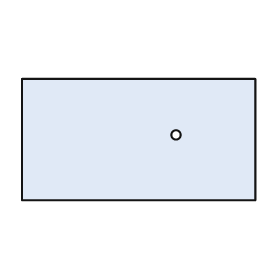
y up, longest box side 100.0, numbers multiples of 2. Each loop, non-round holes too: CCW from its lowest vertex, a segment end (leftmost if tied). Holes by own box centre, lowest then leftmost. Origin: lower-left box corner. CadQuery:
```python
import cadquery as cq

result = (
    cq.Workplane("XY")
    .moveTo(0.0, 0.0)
    .lineTo(100.0, 0.0)
    .lineTo(100.0, 52.0)
    .lineTo(0.0, 52.0)
    .close()
    .moveTo(66.0, 28.0)
    .circle(2.0)
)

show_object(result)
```